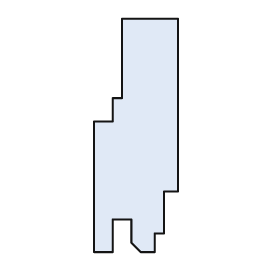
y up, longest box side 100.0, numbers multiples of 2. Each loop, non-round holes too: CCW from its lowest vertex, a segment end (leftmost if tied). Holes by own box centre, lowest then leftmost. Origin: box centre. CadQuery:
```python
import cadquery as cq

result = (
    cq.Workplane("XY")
    .moveTo(-18.0, -50.0)
    .lineTo(-10.0, -50.0)
    .lineTo(-10.0, -36.0)
    .lineTo(-2.0, -36.0)
    .lineTo(-2.0, -46.0)
    .lineTo(2.0, -50.0)
    .lineTo(8.0, -50.0)
    .lineTo(8.0, -42.0)
    .lineTo(12.0, -42.0)
    .lineTo(12.0, -24.0)
    .lineTo(18.0, -24.0)
    .lineTo(18.0, 50.0)
    .lineTo(-6.0, 50.0)
    .lineTo(-6.0, 16.0)
    .lineTo(-10.0, 16.0)
    .lineTo(-10.0, 6.0)
    .lineTo(-18.0, 6.0)
    .close()
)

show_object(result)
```